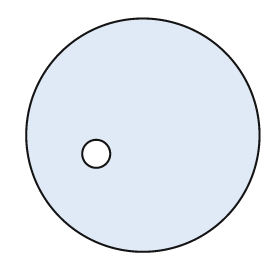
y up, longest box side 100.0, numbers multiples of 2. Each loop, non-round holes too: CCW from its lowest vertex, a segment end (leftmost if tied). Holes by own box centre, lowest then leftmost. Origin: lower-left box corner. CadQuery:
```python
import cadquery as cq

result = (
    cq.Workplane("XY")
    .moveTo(50.0, 50.0)
    .circle(50.0)
    .moveTo(30.0, 42.0)
    .circle(6.0)
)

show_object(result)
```